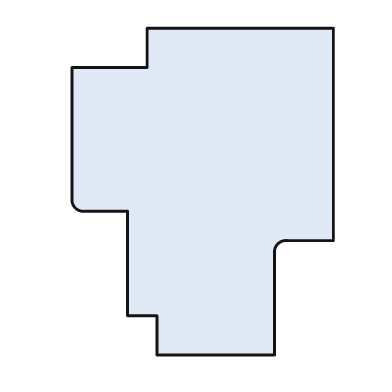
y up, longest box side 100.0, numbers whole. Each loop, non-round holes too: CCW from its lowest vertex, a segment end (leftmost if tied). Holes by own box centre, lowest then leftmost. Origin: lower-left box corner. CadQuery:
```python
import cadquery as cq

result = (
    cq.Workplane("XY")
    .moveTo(26.0, 0.0)
    .lineTo(62.0, 0.0)
    .lineTo(62.0, 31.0)
    .threePointArc((63.0, 34.0), (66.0, 35.0))
    .lineTo(80.0, 35.0)
    .lineTo(80.0, 100.0)
    .lineTo(23.0, 100.0)
    .lineTo(23.0, 88.0)
    .lineTo(0.0, 88.0)
    .lineTo(0.0, 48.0)
    .threePointArc((1.0, 45.0), (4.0, 44.0))
    .lineTo(17.0, 44.0)
    .lineTo(17.0, 12.0)
    .lineTo(26.0, 12.0)
    .close()
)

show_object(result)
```